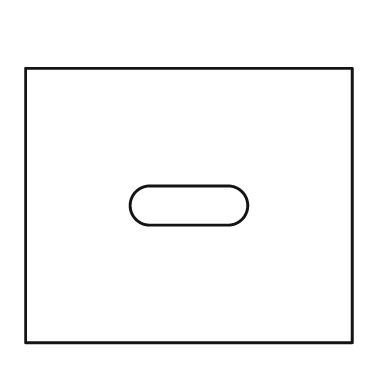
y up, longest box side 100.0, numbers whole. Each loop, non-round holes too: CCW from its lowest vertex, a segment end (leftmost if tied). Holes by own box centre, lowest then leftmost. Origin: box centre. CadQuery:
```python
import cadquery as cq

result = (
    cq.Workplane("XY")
    .moveTo(-50.0, -42.0)
    .lineTo(50.0, -42.0)
    .lineTo(50.0, 42.0)
    .lineTo(-50.0, 42.0)
    .close()
    .moveTo(-12.0, -6.0)
    .lineTo(12.0, -6.0)
    .threePointArc((18.0, 0.0), (12.0, 6.0))
    .lineTo(-12.0, 6.0)
    .threePointArc((-18.0, 0.0), (-12.0, -6.0))
    .close()
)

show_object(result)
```